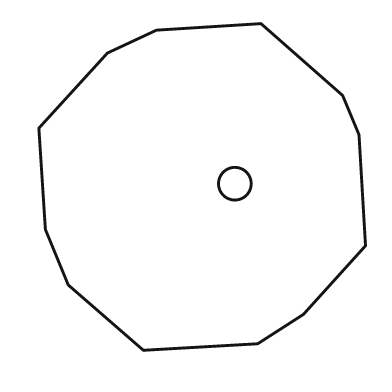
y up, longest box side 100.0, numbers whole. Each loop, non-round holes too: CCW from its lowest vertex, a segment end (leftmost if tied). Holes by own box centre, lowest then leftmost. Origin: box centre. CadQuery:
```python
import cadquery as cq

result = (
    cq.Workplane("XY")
    .moveTo(-18.0, -50.0)
    .lineTo(17.0, -48.0)
    .lineTo(31.0, -39.0)
    .lineTo(50.0, -18.0)
    .lineTo(48.0, 16.0)
    .lineTo(43.0, 28.0)
    .lineTo(18.0, 50.0)
    .lineTo(-14.0, 48.0)
    .lineTo(-29.0, 41.0)
    .lineTo(-50.0, 18.0)
    .lineTo(-48.0, -13.0)
    .lineTo(-41.0, -30.0)
    .close()
    .moveTo(10.0, 1.0)
    .circle(5.0)
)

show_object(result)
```